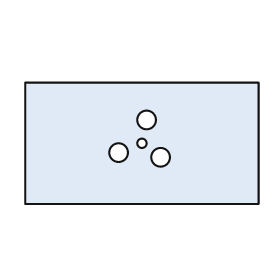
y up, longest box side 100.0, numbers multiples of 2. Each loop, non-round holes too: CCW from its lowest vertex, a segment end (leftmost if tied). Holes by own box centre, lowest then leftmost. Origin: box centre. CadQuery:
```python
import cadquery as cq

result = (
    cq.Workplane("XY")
    .moveTo(-50.0, -26.0)
    .lineTo(50.0, -26.0)
    .lineTo(50.0, 26.0)
    .lineTo(-50.0, 26.0)
    .close()
    .moveTo(8.0, -6.0)
    .circle(4.0)
    .moveTo(-10.0, -4.0)
    .circle(4.0)
    .moveTo(0.0, 0.0)
    .circle(2.0)
    .moveTo(2.0, 10.0)
    .circle(4.0)
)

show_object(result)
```